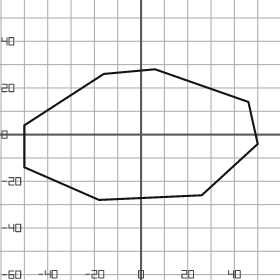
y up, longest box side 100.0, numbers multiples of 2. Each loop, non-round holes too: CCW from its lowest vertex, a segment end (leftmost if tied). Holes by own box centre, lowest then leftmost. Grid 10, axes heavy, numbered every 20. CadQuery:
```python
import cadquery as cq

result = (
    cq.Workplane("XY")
    .moveTo(-18.0, -28.0)
    .lineTo(26.0, -26.0)
    .lineTo(50.0, -4.0)
    .lineTo(46.0, 14.0)
    .lineTo(6.0, 28.0)
    .lineTo(-16.0, 26.0)
    .lineTo(-50.0, 4.0)
    .lineTo(-50.0, -14.0)
    .close()
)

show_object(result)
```